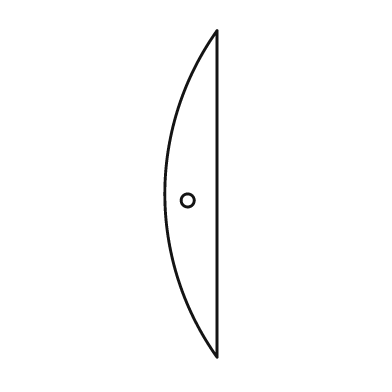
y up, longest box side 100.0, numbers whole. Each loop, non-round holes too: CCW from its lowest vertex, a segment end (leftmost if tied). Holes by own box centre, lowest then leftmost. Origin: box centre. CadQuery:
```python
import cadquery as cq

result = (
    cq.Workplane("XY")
    .moveTo(8.0, -50.0)
    .lineTo(8.0, 50.0)
    .threePointArc((-8.0, 0.0), (8.0, -50.0))
    .close()
    .moveTo(-1.0, -2.0)
    .circle(2.0)
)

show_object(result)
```